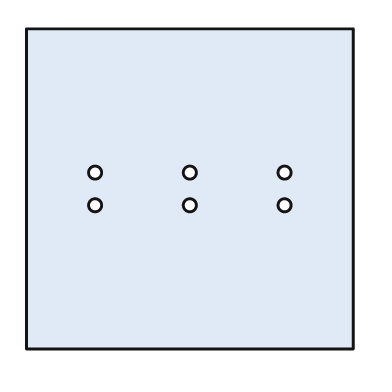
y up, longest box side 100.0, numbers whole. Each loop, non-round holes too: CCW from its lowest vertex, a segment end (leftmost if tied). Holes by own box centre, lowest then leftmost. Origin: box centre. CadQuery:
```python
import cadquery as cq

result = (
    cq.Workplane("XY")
    .moveTo(-50.0, -49.0)
    .lineTo(50.0, -49.0)
    .lineTo(50.0, 49.0)
    .lineTo(-50.0, 49.0)
    .close()
    .moveTo(-29.0, -5.0)
    .circle(2.0)
    .moveTo(0.0, -5.0)
    .circle(2.0)
    .moveTo(29.0, -5.0)
    .circle(2.0)
    .moveTo(-29.0, 5.0)
    .circle(2.0)
    .moveTo(0.0, 5.0)
    .circle(2.0)
    .moveTo(29.0, 5.0)
    .circle(2.0)
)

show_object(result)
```